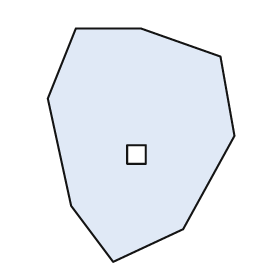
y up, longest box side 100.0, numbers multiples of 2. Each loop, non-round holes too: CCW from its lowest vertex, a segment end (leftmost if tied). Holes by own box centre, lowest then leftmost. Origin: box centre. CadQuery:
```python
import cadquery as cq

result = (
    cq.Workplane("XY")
    .moveTo(-12.0, -50.0)
    .lineTo(18.0, -36.0)
    .lineTo(40.0, 4.0)
    .lineTo(34.0, 38.0)
    .lineTo(0.0, 50.0)
    .lineTo(-28.0, 50.0)
    .lineTo(-40.0, 20.0)
    .lineTo(-30.0, -26.0)
    .close()
    .moveTo(-6.0, -8.0)
    .lineTo(2.0, -8.0)
    .lineTo(2.0, 0.0)
    .lineTo(-6.0, 0.0)
    .close()
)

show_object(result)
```